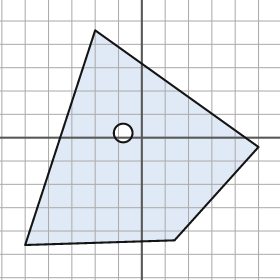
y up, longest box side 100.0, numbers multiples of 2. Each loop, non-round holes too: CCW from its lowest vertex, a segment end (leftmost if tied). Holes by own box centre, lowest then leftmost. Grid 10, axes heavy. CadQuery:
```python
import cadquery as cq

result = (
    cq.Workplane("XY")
    .moveTo(-50.0, -46.0)
    .lineTo(14.0, -44.0)
    .lineTo(50.0, -4.0)
    .lineTo(-20.0, 46.0)
    .close()
    .moveTo(-8.0, 2.0)
    .circle(4.0)
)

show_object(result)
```